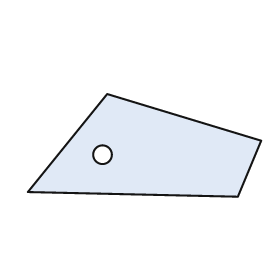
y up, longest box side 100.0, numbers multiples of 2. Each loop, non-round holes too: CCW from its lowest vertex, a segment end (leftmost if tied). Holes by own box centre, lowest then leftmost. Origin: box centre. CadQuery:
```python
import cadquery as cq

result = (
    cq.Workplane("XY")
    .moveTo(40.0, -22.0)
    .lineTo(50.0, 2.0)
    .lineTo(-16.0, 22.0)
    .lineTo(-50.0, -20.0)
    .close()
    .moveTo(-18.0, -4.0)
    .circle(4.0)
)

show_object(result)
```